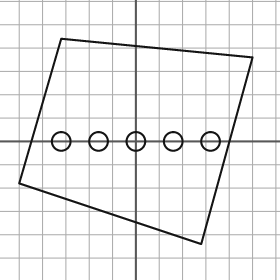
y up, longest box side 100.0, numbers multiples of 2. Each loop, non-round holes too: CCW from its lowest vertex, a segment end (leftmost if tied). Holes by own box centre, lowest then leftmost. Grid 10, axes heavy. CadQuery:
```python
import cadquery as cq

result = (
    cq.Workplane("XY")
    .moveTo(28.0, -44.0)
    .lineTo(50.0, 36.0)
    .lineTo(-32.0, 44.0)
    .lineTo(-50.0, -18.0)
    .close()
    .moveTo(-32.0, 0.0)
    .circle(4.0)
    .moveTo(-16.0, 0.0)
    .circle(4.0)
    .moveTo(0.0, 0.0)
    .circle(4.0)
    .moveTo(16.0, 0.0)
    .circle(4.0)
    .moveTo(32.0, 0.0)
    .circle(4.0)
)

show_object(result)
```